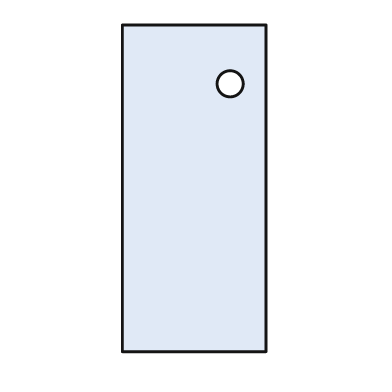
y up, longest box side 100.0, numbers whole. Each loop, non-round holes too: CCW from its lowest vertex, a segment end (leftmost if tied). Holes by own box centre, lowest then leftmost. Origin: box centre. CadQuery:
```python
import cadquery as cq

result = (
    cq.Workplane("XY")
    .moveTo(-22.0, -50.0)
    .lineTo(22.0, -50.0)
    .lineTo(22.0, 50.0)
    .lineTo(-22.0, 50.0)
    .close()
    .moveTo(11.0, 32.0)
    .circle(4.0)
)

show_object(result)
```